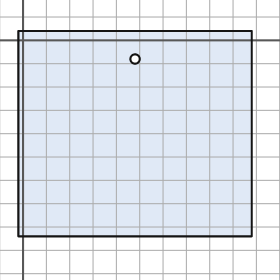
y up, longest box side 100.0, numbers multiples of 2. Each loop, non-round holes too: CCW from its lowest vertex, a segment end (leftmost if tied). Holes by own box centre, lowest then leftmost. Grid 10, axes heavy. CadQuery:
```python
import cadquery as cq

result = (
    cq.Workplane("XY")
    .moveTo(-2.0, -84.0)
    .lineTo(98.0, -84.0)
    .lineTo(98.0, 4.0)
    .lineTo(-2.0, 4.0)
    .close()
    .moveTo(48.0, -8.0)
    .circle(2.0)
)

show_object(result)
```